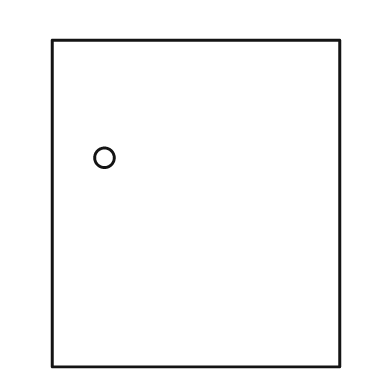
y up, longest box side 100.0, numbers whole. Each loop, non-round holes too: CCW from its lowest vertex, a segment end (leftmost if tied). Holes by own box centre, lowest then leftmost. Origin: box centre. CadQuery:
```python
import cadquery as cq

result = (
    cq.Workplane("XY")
    .moveTo(-44.0, -50.0)
    .lineTo(44.0, -50.0)
    .lineTo(44.0, 50.0)
    .lineTo(-44.0, 50.0)
    .close()
    .moveTo(-28.0, 14.0)
    .circle(3.0)
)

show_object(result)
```